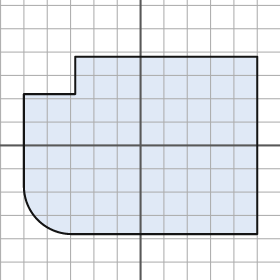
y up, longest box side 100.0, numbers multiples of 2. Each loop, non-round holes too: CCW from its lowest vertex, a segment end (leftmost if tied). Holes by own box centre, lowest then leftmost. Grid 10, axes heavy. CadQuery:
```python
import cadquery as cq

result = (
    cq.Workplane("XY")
    .moveTo(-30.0, -38.0)
    .lineTo(50.0, -38.0)
    .lineTo(50.0, 38.0)
    .lineTo(-28.0, 38.0)
    .lineTo(-28.0, 22.0)
    .lineTo(-50.0, 22.0)
    .lineTo(-50.0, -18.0)
    .threePointArc((-44.0, -32.0), (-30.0, -38.0))
    .close()
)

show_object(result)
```